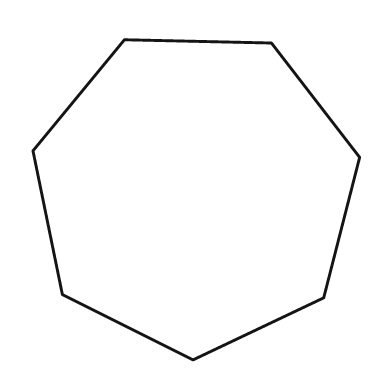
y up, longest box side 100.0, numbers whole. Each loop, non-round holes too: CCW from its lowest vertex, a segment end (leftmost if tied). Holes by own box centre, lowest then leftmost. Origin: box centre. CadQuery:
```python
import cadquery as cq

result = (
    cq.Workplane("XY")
    .moveTo(-1.0, -49.0)
    .lineTo(39.0, -30.0)
    .lineTo(50.0, 13.0)
    .lineTo(23.0, 48.0)
    .lineTo(-22.0, 49.0)
    .lineTo(-50.0, 15.0)
    .lineTo(-41.0, -29.0)
    .close()
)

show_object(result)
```